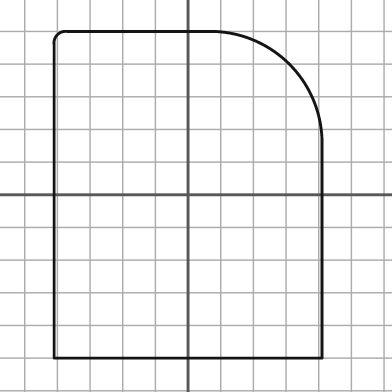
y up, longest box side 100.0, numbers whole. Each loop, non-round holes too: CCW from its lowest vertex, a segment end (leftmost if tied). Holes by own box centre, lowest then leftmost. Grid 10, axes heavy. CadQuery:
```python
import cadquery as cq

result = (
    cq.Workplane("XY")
    .moveTo(-41.0, -50.0)
    .lineTo(41.0, -50.0)
    .lineTo(41.0, 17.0)
    .threePointArc((31.0, 40.0), (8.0, 50.0))
    .lineTo(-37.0, 50.0)
    .threePointArc((-40.0, 49.0), (-41.0, 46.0))
    .close()
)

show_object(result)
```